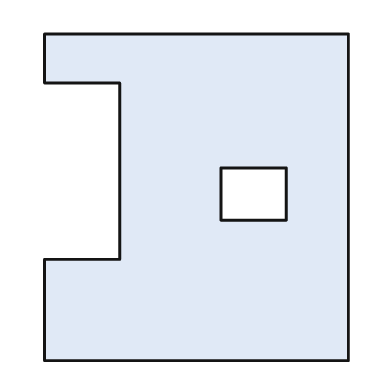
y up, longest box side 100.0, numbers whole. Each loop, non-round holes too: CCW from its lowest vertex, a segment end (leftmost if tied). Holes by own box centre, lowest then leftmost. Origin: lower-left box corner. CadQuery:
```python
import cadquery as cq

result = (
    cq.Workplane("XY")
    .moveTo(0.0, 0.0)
    .lineTo(93.0, 0.0)
    .lineTo(93.0, 100.0)
    .lineTo(0.0, 100.0)
    .lineTo(0.0, 85.0)
    .lineTo(23.0, 85.0)
    .lineTo(23.0, 31.0)
    .lineTo(0.0, 31.0)
    .close()
    .moveTo(54.0, 43.0)
    .lineTo(74.0, 43.0)
    .lineTo(74.0, 59.0)
    .lineTo(54.0, 59.0)
    .close()
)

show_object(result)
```